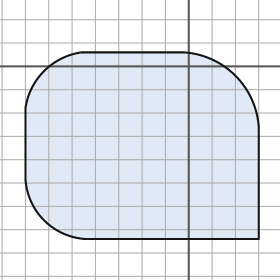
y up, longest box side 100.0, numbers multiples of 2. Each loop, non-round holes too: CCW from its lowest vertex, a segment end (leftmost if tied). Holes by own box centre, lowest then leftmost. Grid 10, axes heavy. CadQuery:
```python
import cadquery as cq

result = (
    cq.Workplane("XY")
    .moveTo(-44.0, -74.0)
    .lineTo(30.0, -74.0)
    .lineTo(30.0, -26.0)
    .threePointArc((20.0, -4.0), (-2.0, 6.0))
    .lineTo(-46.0, 6.0)
    .threePointArc((-62.0, -2.0), (-70.0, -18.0))
    .lineTo(-70.0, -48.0)
    .threePointArc((-62.0, -66.0), (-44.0, -74.0))
    .close()
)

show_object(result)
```